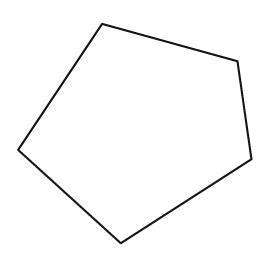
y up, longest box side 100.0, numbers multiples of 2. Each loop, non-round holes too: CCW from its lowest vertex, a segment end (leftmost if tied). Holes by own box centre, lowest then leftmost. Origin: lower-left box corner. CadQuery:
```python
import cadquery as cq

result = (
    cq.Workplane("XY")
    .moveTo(44.0, 0.0)
    .lineTo(100.0, 36.0)
    .lineTo(94.0, 78.0)
    .lineTo(36.0, 94.0)
    .lineTo(0.0, 40.0)
    .close()
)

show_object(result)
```